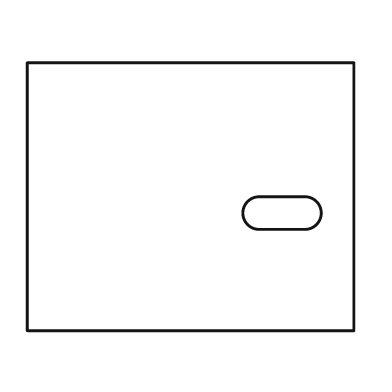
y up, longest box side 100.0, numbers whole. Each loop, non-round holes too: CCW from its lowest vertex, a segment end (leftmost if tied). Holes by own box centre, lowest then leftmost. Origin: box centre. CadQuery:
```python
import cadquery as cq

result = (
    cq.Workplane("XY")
    .moveTo(-50.0, -41.0)
    .lineTo(50.0, -41.0)
    .lineTo(50.0, 41.0)
    .lineTo(-50.0, 41.0)
    .close()
    .moveTo(21.0, -10.0)
    .lineTo(35.0, -10.0)
    .threePointArc((40.0, -5.0), (35.0, 0.0))
    .lineTo(21.0, 0.0)
    .threePointArc((16.0, -5.0), (21.0, -10.0))
    .close()
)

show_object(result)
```